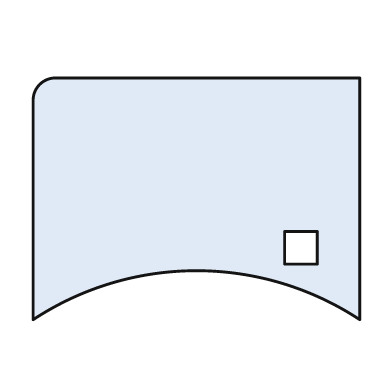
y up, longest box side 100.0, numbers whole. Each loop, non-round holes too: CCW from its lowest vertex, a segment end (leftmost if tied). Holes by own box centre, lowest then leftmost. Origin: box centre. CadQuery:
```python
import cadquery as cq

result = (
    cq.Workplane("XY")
    .moveTo(-50.0, -37.0)
    .threePointArc((0.0, -22.0), (50.0, -37.0))
    .lineTo(50.0, 37.0)
    .lineTo(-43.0, 37.0)
    .threePointArc((-48.0, 35.0), (-50.0, 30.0))
    .close()
    .moveTo(27.0, -20.0)
    .lineTo(37.0, -20.0)
    .lineTo(37.0, -10.0)
    .lineTo(27.0, -10.0)
    .close()
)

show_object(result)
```